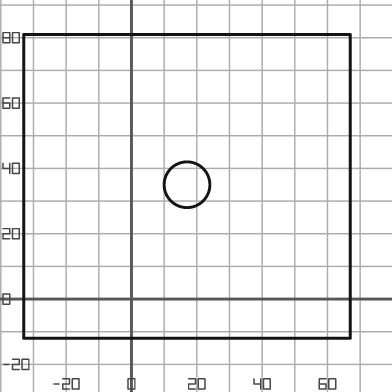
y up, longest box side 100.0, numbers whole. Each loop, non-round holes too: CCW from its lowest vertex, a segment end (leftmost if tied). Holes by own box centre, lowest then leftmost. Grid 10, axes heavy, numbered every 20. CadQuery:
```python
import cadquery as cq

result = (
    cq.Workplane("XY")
    .moveTo(-33.0, -12.0)
    .lineTo(67.0, -12.0)
    .lineTo(67.0, 81.0)
    .lineTo(-33.0, 81.0)
    .close()
    .moveTo(17.0, 35.0)
    .circle(7.0)
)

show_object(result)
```